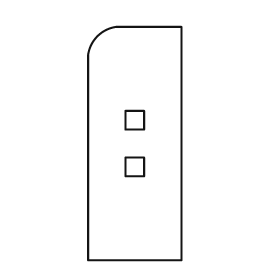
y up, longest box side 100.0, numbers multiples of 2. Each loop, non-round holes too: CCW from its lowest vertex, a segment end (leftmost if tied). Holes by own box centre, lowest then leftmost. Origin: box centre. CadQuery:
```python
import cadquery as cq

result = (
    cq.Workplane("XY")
    .moveTo(-20.0, -50.0)
    .lineTo(20.0, -50.0)
    .lineTo(20.0, 50.0)
    .lineTo(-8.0, 50.0)
    .threePointArc((-16.0, 46.0), (-20.0, 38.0))
    .close()
    .moveTo(-4.0, -14.0)
    .lineTo(4.0, -14.0)
    .lineTo(4.0, -6.0)
    .lineTo(-4.0, -6.0)
    .close()
    .moveTo(-4.0, 6.0)
    .lineTo(4.0, 6.0)
    .lineTo(4.0, 14.0)
    .lineTo(-4.0, 14.0)
    .close()
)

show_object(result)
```